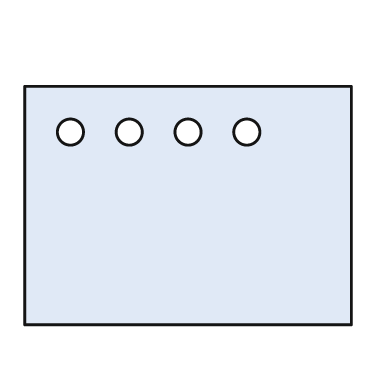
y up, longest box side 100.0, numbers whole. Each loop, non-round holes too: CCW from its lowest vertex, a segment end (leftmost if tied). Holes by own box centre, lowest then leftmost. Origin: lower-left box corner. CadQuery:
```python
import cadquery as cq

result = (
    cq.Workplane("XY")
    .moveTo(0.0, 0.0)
    .lineTo(100.0, 0.0)
    .lineTo(100.0, 73.0)
    .lineTo(0.0, 73.0)
    .close()
    .moveTo(14.0, 59.0)
    .circle(4.0)
    .moveTo(32.0, 59.0)
    .circle(4.0)
    .moveTo(50.0, 59.0)
    .circle(4.0)
    .moveTo(68.0, 59.0)
    .circle(4.0)
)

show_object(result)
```